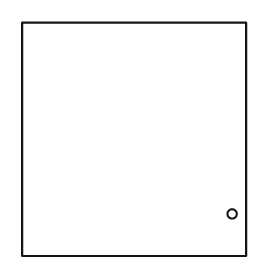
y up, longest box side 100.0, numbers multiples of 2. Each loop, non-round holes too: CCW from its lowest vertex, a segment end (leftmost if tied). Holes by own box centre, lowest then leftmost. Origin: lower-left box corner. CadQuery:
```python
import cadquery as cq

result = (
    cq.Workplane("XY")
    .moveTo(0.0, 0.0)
    .lineTo(96.0, 0.0)
    .lineTo(96.0, 100.0)
    .lineTo(0.0, 100.0)
    .close()
    .moveTo(90.0, 18.0)
    .circle(2.0)
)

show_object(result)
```